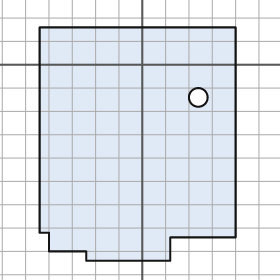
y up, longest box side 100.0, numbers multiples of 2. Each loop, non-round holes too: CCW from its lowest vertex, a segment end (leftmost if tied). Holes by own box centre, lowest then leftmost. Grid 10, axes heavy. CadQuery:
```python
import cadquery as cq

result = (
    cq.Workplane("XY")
    .moveTo(-24.0, -84.0)
    .lineTo(12.0, -84.0)
    .lineTo(12.0, -74.0)
    .lineTo(40.0, -74.0)
    .lineTo(40.0, 16.0)
    .lineTo(-44.0, 16.0)
    .lineTo(-44.0, -72.0)
    .lineTo(-40.0, -72.0)
    .lineTo(-40.0, -80.0)
    .lineTo(-24.0, -80.0)
    .close()
    .moveTo(24.0, -14.0)
    .circle(4.0)
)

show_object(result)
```